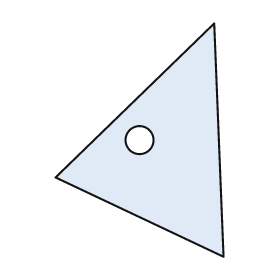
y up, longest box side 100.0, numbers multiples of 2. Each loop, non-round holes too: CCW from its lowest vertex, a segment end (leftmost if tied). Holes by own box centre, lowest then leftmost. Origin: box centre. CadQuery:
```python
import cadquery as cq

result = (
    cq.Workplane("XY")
    .moveTo(36.0, -50.0)
    .lineTo(32.0, 50.0)
    .lineTo(-36.0, -16.0)
    .close()
    .moveTo(0.0, 0.0)
    .circle(6.0)
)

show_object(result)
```